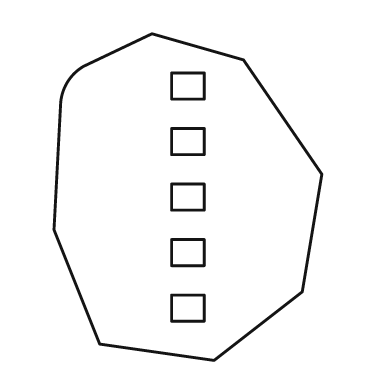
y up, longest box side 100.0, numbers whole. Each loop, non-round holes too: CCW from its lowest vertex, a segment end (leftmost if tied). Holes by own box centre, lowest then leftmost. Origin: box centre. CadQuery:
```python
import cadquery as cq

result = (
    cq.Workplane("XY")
    .moveTo(8.0, -50.0)
    .lineTo(35.0, -29.0)
    .lineTo(41.0, 7.0)
    .lineTo(17.0, 42.0)
    .lineTo(-11.0, 50.0)
    .lineTo(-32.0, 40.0)
    .threePointArc((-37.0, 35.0), (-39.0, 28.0))
    .lineTo(-41.0, -10.0)
    .lineTo(-27.0, -45.0)
    .close()
    .moveTo(-5.0, -38.0)
    .lineTo(5.0, -38.0)
    .lineTo(5.0, -30.0)
    .lineTo(-5.0, -30.0)
    .close()
    .moveTo(-5.0, -21.0)
    .lineTo(5.0, -21.0)
    .lineTo(5.0, -13.0)
    .lineTo(-5.0, -13.0)
    .close()
    .moveTo(-5.0, -4.0)
    .lineTo(5.0, -4.0)
    .lineTo(5.0, 4.0)
    .lineTo(-5.0, 4.0)
    .close()
    .moveTo(-5.0, 13.0)
    .lineTo(5.0, 13.0)
    .lineTo(5.0, 21.0)
    .lineTo(-5.0, 21.0)
    .close()
    .moveTo(-5.0, 30.0)
    .lineTo(5.0, 30.0)
    .lineTo(5.0, 38.0)
    .lineTo(-5.0, 38.0)
    .close()
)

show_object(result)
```